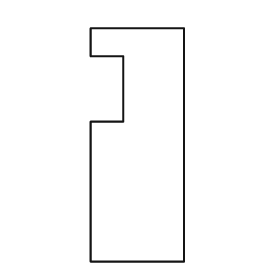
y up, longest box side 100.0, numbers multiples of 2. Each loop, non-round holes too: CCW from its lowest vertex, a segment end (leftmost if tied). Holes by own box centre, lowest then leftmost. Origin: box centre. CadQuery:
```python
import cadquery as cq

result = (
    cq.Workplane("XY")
    .moveTo(-20.0, -50.0)
    .lineTo(20.0, -50.0)
    .lineTo(20.0, 50.0)
    .lineTo(-20.0, 50.0)
    .lineTo(-20.0, 38.0)
    .lineTo(-6.0, 38.0)
    .lineTo(-6.0, 10.0)
    .lineTo(-20.0, 10.0)
    .close()
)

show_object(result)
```